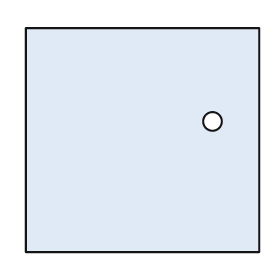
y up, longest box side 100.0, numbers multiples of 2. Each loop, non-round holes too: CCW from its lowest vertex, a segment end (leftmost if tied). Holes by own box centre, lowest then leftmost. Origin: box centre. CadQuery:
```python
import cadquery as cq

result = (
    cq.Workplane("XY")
    .moveTo(-50.0, -48.0)
    .lineTo(50.0, -48.0)
    .lineTo(50.0, 48.0)
    .lineTo(-50.0, 48.0)
    .close()
    .moveTo(30.0, 8.0)
    .circle(4.0)
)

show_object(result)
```